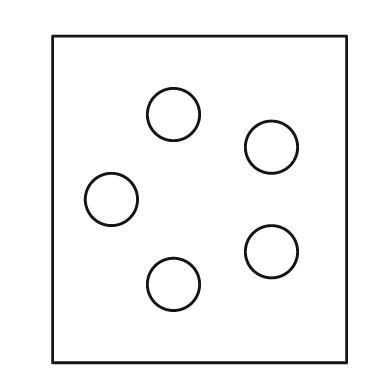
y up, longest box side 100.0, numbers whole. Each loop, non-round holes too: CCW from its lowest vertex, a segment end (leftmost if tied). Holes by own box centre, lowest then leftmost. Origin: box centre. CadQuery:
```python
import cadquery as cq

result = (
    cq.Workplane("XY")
    .moveTo(-45.0, -50.0)
    .lineTo(45.0, -50.0)
    .lineTo(45.0, 50.0)
    .lineTo(-45.0, 50.0)
    .close()
    .moveTo(-8.0, -26.0)
    .circle(8.0)
    .moveTo(22.0, -16.0)
    .circle(8.0)
    .moveTo(-27.0, 0.0)
    .circle(8.0)
    .moveTo(22.0, 16.0)
    .circle(8.0)
    .moveTo(-8.0, 26.0)
    .circle(8.0)
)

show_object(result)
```